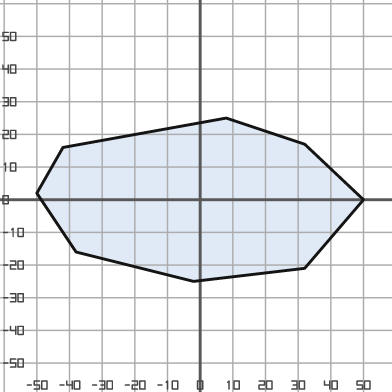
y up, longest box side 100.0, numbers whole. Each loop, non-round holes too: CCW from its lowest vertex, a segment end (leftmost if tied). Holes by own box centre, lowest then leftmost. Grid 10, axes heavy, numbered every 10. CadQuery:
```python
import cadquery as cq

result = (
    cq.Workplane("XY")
    .moveTo(-2.0, -25.0)
    .lineTo(32.0, -21.0)
    .lineTo(50.0, 0.0)
    .lineTo(32.0, 17.0)
    .lineTo(8.0, 25.0)
    .lineTo(-42.0, 16.0)
    .lineTo(-50.0, 2.0)
    .lineTo(-38.0, -16.0)
    .close()
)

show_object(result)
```